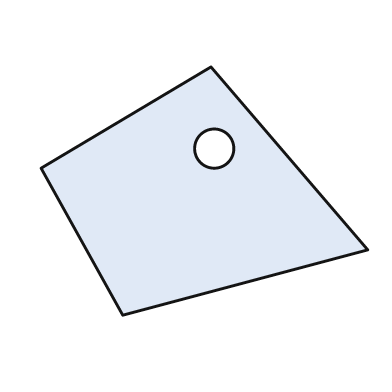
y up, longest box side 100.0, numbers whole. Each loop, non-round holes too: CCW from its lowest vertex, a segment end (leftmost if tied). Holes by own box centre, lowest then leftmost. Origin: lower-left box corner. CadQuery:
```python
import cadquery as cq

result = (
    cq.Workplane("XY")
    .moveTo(25.0, 0.0)
    .lineTo(100.0, 20.0)
    .lineTo(52.0, 76.0)
    .lineTo(0.0, 45.0)
    .close()
    .moveTo(53.0, 51.0)
    .circle(6.0)
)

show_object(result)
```